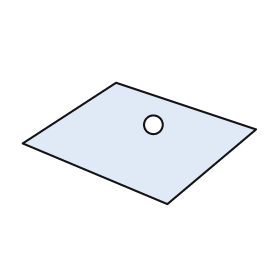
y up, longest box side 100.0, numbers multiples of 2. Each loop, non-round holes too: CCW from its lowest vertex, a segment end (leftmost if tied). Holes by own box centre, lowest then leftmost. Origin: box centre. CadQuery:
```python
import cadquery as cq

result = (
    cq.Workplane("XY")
    .moveTo(12.0, -26.0)
    .lineTo(50.0, 6.0)
    .lineTo(-10.0, 26.0)
    .lineTo(-50.0, 0.0)
    .close()
    .moveTo(6.0, 8.0)
    .circle(4.0)
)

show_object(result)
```